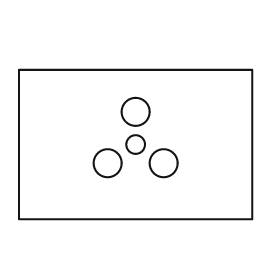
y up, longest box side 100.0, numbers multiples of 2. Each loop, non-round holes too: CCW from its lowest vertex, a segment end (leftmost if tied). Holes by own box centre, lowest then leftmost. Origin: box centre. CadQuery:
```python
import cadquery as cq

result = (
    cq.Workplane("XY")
    .moveTo(-50.0, -32.0)
    .lineTo(50.0, -32.0)
    .lineTo(50.0, 32.0)
    .lineTo(-50.0, 32.0)
    .close()
    .moveTo(-12.0, -8.0)
    .circle(6.0)
    .moveTo(12.0, -8.0)
    .circle(6.0)
    .moveTo(0.0, 0.0)
    .circle(4.0)
    .moveTo(0.0, 14.0)
    .circle(6.0)
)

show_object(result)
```